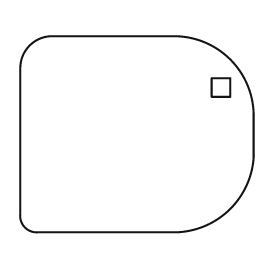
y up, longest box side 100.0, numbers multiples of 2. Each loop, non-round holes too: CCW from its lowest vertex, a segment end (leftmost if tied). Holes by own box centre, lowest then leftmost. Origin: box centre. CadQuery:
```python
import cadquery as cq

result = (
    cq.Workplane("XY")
    .moveTo(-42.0, -42.0)
    .lineTo(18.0, -42.0)
    .threePointArc((40.0, -32.0), (50.0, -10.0))
    .lineTo(50.0, 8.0)
    .threePointArc((40.0, 32.0), (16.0, 42.0))
    .lineTo(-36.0, 42.0)
    .threePointArc((-46.0, 38.0), (-50.0, 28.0))
    .lineTo(-50.0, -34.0)
    .threePointArc((-48.0, -40.0), (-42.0, -42.0))
    .close()
    .moveTo(32.0, 16.0)
    .lineTo(40.0, 16.0)
    .lineTo(40.0, 24.0)
    .lineTo(32.0, 24.0)
    .close()
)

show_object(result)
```